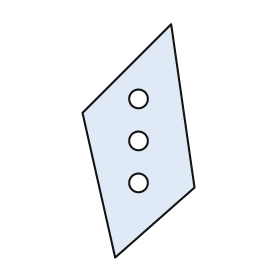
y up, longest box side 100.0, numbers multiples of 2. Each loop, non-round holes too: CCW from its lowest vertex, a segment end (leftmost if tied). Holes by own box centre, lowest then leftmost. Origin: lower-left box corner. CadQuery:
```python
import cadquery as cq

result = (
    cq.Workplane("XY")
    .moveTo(14.0, 0.0)
    .lineTo(48.0, 30.0)
    .lineTo(38.0, 100.0)
    .lineTo(0.0, 62.0)
    .close()
    .moveTo(24.0, 32.0)
    .circle(4.0)
    .moveTo(24.0, 50.0)
    .circle(4.0)
    .moveTo(24.0, 68.0)
    .circle(4.0)
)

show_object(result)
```